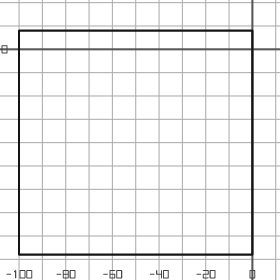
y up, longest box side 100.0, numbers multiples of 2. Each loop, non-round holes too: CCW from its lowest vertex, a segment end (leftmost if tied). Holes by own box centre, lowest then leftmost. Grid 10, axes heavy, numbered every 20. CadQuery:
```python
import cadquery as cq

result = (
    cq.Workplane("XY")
    .moveTo(-100.0, -88.0)
    .lineTo(0.0, -88.0)
    .lineTo(0.0, 8.0)
    .lineTo(-100.0, 8.0)
    .close()
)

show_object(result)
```